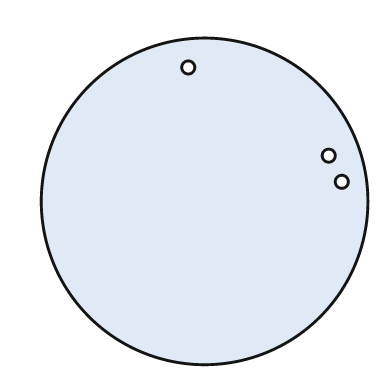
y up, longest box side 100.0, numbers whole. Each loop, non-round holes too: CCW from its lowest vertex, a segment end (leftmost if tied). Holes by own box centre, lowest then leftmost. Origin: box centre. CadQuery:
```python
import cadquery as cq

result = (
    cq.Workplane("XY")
    .moveTo(0.0, 0.0)
    .circle(50.0)
    .moveTo(42.0, 6.0)
    .circle(2.0)
    .moveTo(38.0, 14.0)
    .circle(2.0)
    .moveTo(-5.0, 41.0)
    .circle(2.0)
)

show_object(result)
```